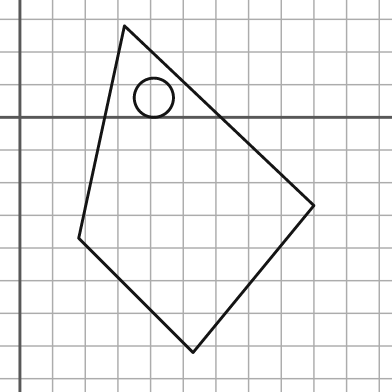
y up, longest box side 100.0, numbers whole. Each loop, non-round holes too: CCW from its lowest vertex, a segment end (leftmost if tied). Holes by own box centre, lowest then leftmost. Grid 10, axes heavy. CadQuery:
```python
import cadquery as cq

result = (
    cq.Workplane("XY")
    .moveTo(53.0, -72.0)
    .lineTo(90.0, -27.0)
    .lineTo(32.0, 28.0)
    .lineTo(18.0, -37.0)
    .close()
    .moveTo(41.0, 6.0)
    .circle(6.0)
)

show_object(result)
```